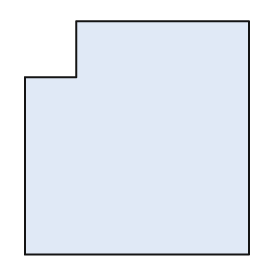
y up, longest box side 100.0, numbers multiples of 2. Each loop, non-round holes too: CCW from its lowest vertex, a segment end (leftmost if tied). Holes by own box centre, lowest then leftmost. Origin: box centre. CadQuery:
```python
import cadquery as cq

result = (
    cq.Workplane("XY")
    .moveTo(-48.0, -50.0)
    .lineTo(48.0, -50.0)
    .lineTo(48.0, 50.0)
    .lineTo(-26.0, 50.0)
    .lineTo(-26.0, 26.0)
    .lineTo(-48.0, 26.0)
    .close()
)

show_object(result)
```